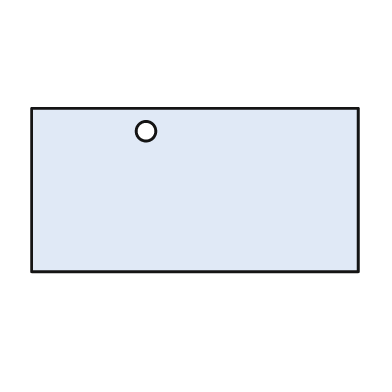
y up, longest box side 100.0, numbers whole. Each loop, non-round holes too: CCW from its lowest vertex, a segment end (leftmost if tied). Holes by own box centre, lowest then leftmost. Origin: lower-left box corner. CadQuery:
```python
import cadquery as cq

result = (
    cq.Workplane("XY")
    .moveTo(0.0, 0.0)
    .lineTo(100.0, 0.0)
    .lineTo(100.0, 50.0)
    .lineTo(0.0, 50.0)
    .close()
    .moveTo(35.0, 43.0)
    .circle(3.0)
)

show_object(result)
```